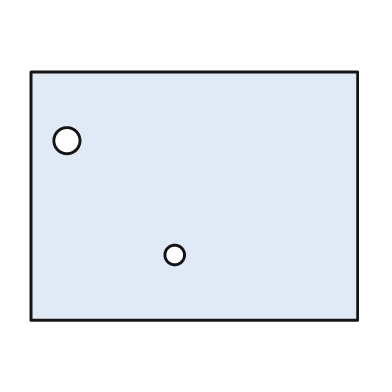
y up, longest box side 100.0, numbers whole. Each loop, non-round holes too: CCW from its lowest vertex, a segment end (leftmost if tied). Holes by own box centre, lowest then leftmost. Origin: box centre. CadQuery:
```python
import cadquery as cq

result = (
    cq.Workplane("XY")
    .moveTo(-50.0, -38.0)
    .lineTo(50.0, -38.0)
    .lineTo(50.0, 38.0)
    .lineTo(-50.0, 38.0)
    .close()
    .moveTo(-6.0, -18.0)
    .circle(3.0)
    .moveTo(-39.0, 17.0)
    .circle(4.0)
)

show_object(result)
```